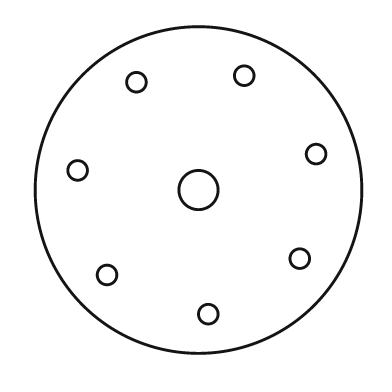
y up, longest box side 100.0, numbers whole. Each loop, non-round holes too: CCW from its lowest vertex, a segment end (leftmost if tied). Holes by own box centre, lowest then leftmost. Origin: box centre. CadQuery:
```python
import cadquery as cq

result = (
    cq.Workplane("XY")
    .moveTo(0.0, 0.0)
    .circle(50.0)
    .moveTo(3.0, -38.0)
    .circle(3.0)
    .moveTo(-28.0, -26.0)
    .circle(3.0)
    .moveTo(31.0, -21.0)
    .circle(3.0)
    .moveTo(0.0, 0.0)
    .circle(6.0)
    .moveTo(-37.0, 6.0)
    .circle(3.0)
    .moveTo(36.0, 11.0)
    .circle(3.0)
    .moveTo(-19.0, 33.0)
    .circle(3.0)
    .moveTo(14.0, 35.0)
    .circle(3.0)
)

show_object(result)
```